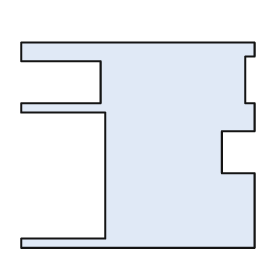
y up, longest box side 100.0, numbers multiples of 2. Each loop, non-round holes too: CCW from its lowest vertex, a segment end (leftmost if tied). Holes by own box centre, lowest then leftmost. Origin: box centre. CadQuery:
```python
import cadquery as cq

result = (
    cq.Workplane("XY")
    .moveTo(-50.0, -44.0)
    .lineTo(50.0, -44.0)
    .lineTo(50.0, -12.0)
    .lineTo(36.0, -12.0)
    .lineTo(36.0, 6.0)
    .lineTo(50.0, 6.0)
    .lineTo(50.0, 18.0)
    .lineTo(46.0, 18.0)
    .lineTo(46.0, 38.0)
    .lineTo(50.0, 38.0)
    .lineTo(50.0, 44.0)
    .lineTo(-50.0, 44.0)
    .lineTo(-50.0, 36.0)
    .lineTo(-16.0, 36.0)
    .lineTo(-16.0, 18.0)
    .lineTo(-50.0, 18.0)
    .lineTo(-50.0, 14.0)
    .lineTo(-14.0, 14.0)
    .lineTo(-14.0, -40.0)
    .lineTo(-50.0, -40.0)
    .close()
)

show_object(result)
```